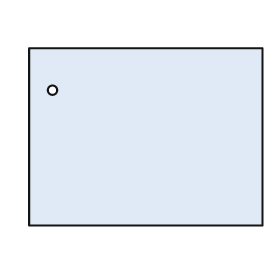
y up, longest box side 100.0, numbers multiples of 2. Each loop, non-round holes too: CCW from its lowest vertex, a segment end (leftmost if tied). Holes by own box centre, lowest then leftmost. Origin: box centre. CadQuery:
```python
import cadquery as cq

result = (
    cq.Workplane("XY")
    .moveTo(-50.0, -38.0)
    .lineTo(50.0, -38.0)
    .lineTo(50.0, 38.0)
    .lineTo(-50.0, 38.0)
    .close()
    .moveTo(-40.0, 20.0)
    .circle(2.0)
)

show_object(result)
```